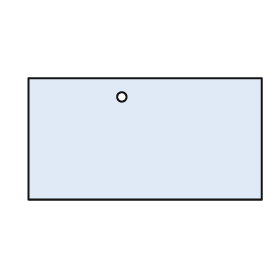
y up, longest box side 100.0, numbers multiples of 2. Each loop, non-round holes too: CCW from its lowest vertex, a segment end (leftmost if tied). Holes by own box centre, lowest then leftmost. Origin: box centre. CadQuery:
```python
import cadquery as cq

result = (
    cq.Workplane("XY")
    .moveTo(-50.0, -26.0)
    .lineTo(50.0, -26.0)
    .lineTo(50.0, 26.0)
    .lineTo(-50.0, 26.0)
    .close()
    .moveTo(-10.0, 18.0)
    .circle(2.0)
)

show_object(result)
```